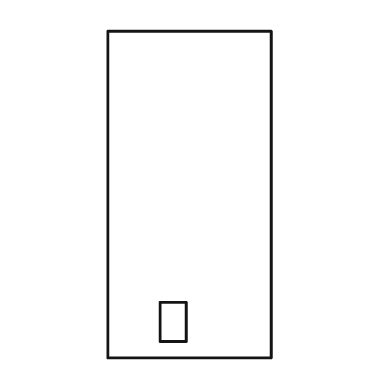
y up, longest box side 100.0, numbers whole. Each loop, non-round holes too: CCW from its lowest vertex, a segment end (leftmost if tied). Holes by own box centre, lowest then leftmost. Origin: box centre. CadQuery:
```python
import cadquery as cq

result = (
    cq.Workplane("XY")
    .moveTo(-25.0, -50.0)
    .lineTo(25.0, -50.0)
    .lineTo(25.0, 50.0)
    .lineTo(-25.0, 50.0)
    .close()
    .moveTo(-9.0, -45.0)
    .lineTo(-1.0, -45.0)
    .lineTo(-1.0, -33.0)
    .lineTo(-9.0, -33.0)
    .close()
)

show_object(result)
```